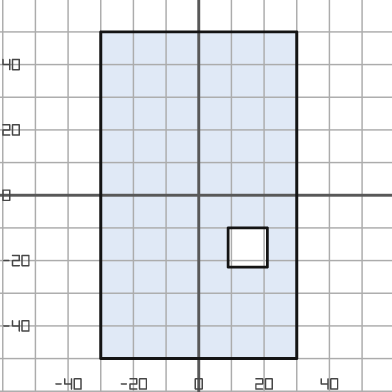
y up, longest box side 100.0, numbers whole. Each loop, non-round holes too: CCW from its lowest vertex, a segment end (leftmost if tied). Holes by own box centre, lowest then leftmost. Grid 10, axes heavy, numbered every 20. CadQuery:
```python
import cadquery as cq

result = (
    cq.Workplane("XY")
    .moveTo(-30.0, -50.0)
    .lineTo(30.0, -50.0)
    .lineTo(30.0, 50.0)
    .lineTo(-30.0, 50.0)
    .close()
    .moveTo(9.0, -22.0)
    .lineTo(21.0, -22.0)
    .lineTo(21.0, -10.0)
    .lineTo(9.0, -10.0)
    .close()
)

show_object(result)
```